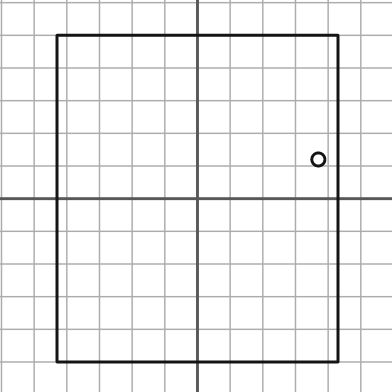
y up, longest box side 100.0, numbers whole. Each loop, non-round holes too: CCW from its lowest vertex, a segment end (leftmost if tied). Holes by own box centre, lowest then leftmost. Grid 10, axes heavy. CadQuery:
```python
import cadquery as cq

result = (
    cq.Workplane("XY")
    .moveTo(-43.0, -50.0)
    .lineTo(43.0, -50.0)
    .lineTo(43.0, 50.0)
    .lineTo(-43.0, 50.0)
    .close()
    .moveTo(37.0, 12.0)
    .circle(2.0)
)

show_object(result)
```